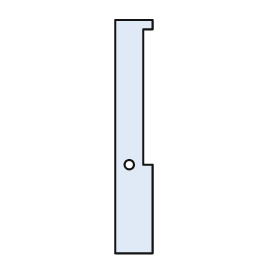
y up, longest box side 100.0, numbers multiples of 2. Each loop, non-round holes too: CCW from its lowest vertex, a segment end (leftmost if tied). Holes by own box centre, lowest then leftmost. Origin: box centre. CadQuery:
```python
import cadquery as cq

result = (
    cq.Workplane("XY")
    .moveTo(-8.0, -50.0)
    .lineTo(8.0, -50.0)
    .lineTo(8.0, -12.0)
    .lineTo(4.0, -12.0)
    .lineTo(4.0, 46.0)
    .lineTo(8.0, 46.0)
    .lineTo(8.0, 50.0)
    .lineTo(-8.0, 50.0)
    .close()
    .moveTo(-2.0, -12.0)
    .circle(2.0)
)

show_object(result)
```